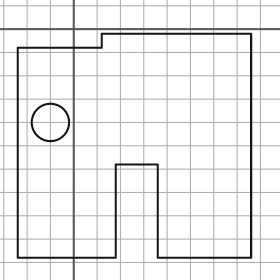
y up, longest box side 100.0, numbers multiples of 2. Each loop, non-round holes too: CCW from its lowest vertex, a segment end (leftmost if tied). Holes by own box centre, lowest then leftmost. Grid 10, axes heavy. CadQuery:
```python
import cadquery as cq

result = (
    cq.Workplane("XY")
    .moveTo(-24.0, -98.0)
    .lineTo(18.0, -98.0)
    .lineTo(18.0, -58.0)
    .lineTo(36.0, -58.0)
    .lineTo(36.0, -98.0)
    .lineTo(76.0, -98.0)
    .lineTo(76.0, -2.0)
    .lineTo(12.0, -2.0)
    .lineTo(12.0, -8.0)
    .lineTo(-24.0, -8.0)
    .close()
    .moveTo(-10.0, -40.0)
    .circle(8.0)
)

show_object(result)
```